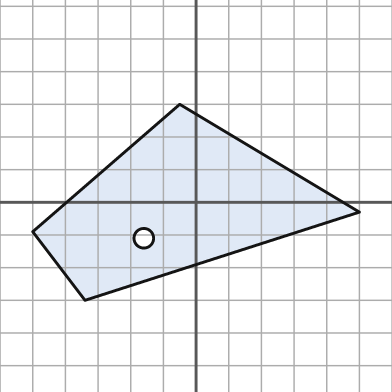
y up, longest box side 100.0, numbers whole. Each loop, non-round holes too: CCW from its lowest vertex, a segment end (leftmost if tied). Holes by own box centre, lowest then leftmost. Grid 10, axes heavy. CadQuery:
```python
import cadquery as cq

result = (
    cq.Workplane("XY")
    .moveTo(-34.0, -30.0)
    .lineTo(50.0, -3.0)
    .lineTo(-5.0, 30.0)
    .lineTo(-50.0, -9.0)
    .close()
    .moveTo(-16.0, -11.0)
    .circle(3.0)
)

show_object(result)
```